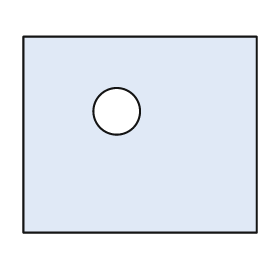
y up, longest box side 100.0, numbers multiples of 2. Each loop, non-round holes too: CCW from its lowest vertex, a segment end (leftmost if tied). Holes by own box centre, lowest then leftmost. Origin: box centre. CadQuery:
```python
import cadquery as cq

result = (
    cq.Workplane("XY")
    .moveTo(-50.0, -42.0)
    .lineTo(50.0, -42.0)
    .lineTo(50.0, 42.0)
    .lineTo(-50.0, 42.0)
    .close()
    .moveTo(-10.0, 10.0)
    .circle(10.0)
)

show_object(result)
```